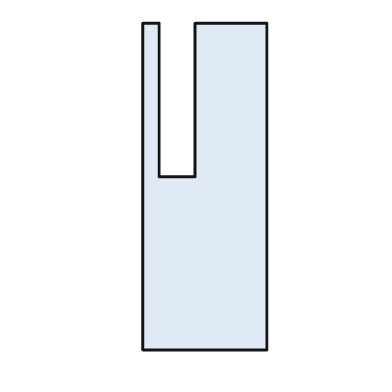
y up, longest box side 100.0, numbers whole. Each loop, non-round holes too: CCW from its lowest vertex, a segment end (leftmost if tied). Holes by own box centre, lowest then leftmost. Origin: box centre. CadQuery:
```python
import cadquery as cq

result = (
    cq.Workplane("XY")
    .moveTo(-19.0, -50.0)
    .lineTo(19.0, -50.0)
    .lineTo(19.0, 50.0)
    .lineTo(-3.0, 50.0)
    .lineTo(-3.0, 3.0)
    .lineTo(-14.0, 3.0)
    .lineTo(-14.0, 50.0)
    .lineTo(-19.0, 50.0)
    .close()
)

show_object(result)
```